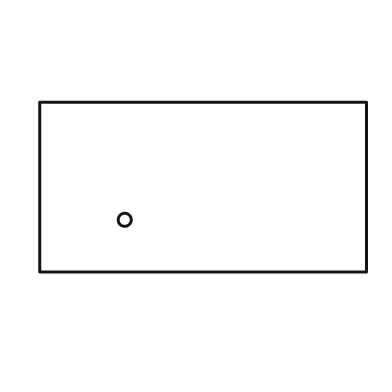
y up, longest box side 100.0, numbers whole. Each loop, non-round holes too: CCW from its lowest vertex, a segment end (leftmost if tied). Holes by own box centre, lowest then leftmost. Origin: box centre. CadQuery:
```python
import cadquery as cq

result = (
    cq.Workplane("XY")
    .moveTo(-50.0, -26.0)
    .lineTo(50.0, -26.0)
    .lineTo(50.0, 26.0)
    .lineTo(-50.0, 26.0)
    .close()
    .moveTo(-24.0, -10.0)
    .circle(2.0)
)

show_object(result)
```